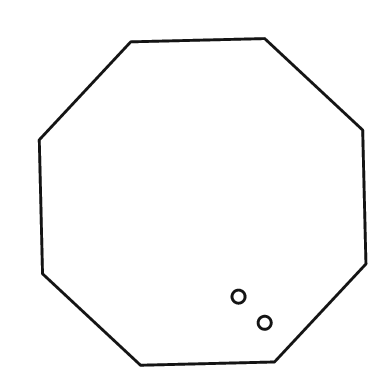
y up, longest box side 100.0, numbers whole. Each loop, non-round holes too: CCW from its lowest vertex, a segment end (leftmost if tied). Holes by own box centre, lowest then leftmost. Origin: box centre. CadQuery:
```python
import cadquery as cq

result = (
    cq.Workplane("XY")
    .moveTo(-19.0, -50.0)
    .lineTo(22.0, -49.0)
    .lineTo(50.0, -19.0)
    .lineTo(49.0, 22.0)
    .lineTo(19.0, 50.0)
    .lineTo(-22.0, 49.0)
    .lineTo(-50.0, 19.0)
    .lineTo(-49.0, -22.0)
    .close()
    .moveTo(19.0, -37.0)
    .circle(2.0)
    .moveTo(11.0, -29.0)
    .circle(2.0)
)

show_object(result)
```